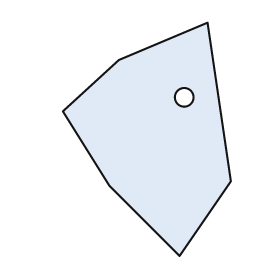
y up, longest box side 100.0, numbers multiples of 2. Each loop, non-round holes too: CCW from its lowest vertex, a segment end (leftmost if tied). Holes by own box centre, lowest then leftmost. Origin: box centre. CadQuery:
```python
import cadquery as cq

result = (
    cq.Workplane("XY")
    .moveTo(14.0, -50.0)
    .lineTo(36.0, -18.0)
    .lineTo(26.0, 50.0)
    .lineTo(-12.0, 34.0)
    .lineTo(-36.0, 12.0)
    .lineTo(-16.0, -20.0)
    .close()
    .moveTo(16.0, 18.0)
    .circle(4.0)
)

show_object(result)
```